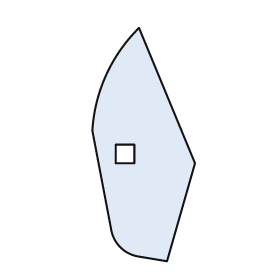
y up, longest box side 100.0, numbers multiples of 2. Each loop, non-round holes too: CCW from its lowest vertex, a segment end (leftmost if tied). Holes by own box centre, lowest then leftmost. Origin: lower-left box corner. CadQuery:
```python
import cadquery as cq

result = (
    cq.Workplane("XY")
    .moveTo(32.0, 0.0)
    .lineTo(44.0, 42.0)
    .lineTo(20.0, 100.0)
    .threePointArc((6.0, 80.0), (0.0, 56.0))
    .lineTo(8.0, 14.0)
    .threePointArc((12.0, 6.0), (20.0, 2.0))
    .close()
    .moveTo(10.0, 42.0)
    .lineTo(18.0, 42.0)
    .lineTo(18.0, 50.0)
    .lineTo(10.0, 50.0)
    .close()
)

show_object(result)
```